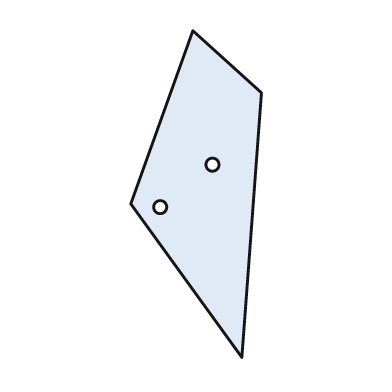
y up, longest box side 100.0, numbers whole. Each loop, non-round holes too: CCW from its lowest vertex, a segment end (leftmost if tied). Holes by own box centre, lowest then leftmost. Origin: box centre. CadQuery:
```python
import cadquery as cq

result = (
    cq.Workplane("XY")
    .moveTo(14.0, -50.0)
    .lineTo(20.0, 31.0)
    .lineTo(-1.0, 50.0)
    .lineTo(-20.0, -3.0)
    .close()
    .moveTo(-11.0, -4.0)
    .circle(2.0)
    .moveTo(5.0, 9.0)
    .circle(2.0)
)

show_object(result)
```